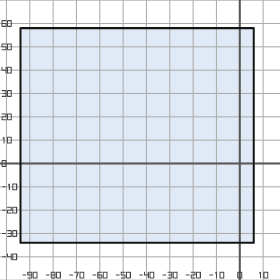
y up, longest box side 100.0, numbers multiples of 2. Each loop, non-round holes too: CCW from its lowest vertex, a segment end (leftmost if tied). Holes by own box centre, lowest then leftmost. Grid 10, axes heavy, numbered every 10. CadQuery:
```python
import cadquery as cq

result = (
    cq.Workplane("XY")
    .moveTo(-94.0, -34.0)
    .lineTo(6.0, -34.0)
    .lineTo(6.0, 58.0)
    .lineTo(-94.0, 58.0)
    .close()
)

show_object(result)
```